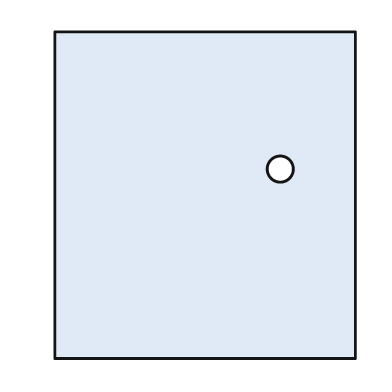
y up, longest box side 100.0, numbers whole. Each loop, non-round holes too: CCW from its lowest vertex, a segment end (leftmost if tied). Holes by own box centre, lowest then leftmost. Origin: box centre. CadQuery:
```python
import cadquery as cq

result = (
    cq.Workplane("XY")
    .moveTo(-46.0, -50.0)
    .lineTo(46.0, -50.0)
    .lineTo(46.0, 50.0)
    .lineTo(-46.0, 50.0)
    .close()
    .moveTo(23.0, 8.0)
    .circle(4.0)
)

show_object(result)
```